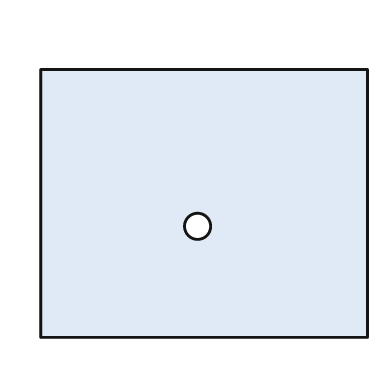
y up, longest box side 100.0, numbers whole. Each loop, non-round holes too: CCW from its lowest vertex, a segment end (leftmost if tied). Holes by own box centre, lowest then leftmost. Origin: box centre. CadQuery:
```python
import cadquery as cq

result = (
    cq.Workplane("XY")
    .moveTo(-50.0, -41.0)
    .lineTo(50.0, -41.0)
    .lineTo(50.0, 41.0)
    .lineTo(-50.0, 41.0)
    .close()
    .moveTo(-2.0, -7.0)
    .circle(4.0)
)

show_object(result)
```